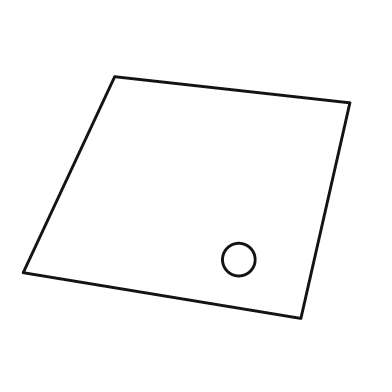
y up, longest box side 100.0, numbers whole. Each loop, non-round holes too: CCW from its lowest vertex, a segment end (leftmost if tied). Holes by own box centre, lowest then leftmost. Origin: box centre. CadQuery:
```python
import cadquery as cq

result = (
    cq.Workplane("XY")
    .moveTo(35.0, -37.0)
    .lineTo(50.0, 29.0)
    .lineTo(-22.0, 37.0)
    .lineTo(-50.0, -23.0)
    .close()
    .moveTo(16.0, -19.0)
    .circle(5.0)
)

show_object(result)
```